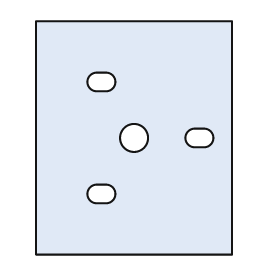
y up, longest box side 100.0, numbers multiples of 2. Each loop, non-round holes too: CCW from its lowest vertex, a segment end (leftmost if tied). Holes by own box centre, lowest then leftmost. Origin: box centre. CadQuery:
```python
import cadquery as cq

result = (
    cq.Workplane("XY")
    .moveTo(-42.0, -50.0)
    .lineTo(42.0, -50.0)
    .lineTo(42.0, 50.0)
    .lineTo(-42.0, 50.0)
    .close()
    .moveTo(-16.0, -28.0)
    .lineTo(-12.0, -28.0)
    .threePointArc((-8.0, -24.0), (-12.0, -20.0))
    .lineTo(-16.0, -20.0)
    .threePointArc((-20.0, -24.0), (-16.0, -28.0))
    .close()
    .moveTo(0.0, 0.0)
    .circle(6.0)
    .moveTo(26.0, -4.0)
    .lineTo(30.0, -4.0)
    .threePointArc((34.0, 0.0), (30.0, 4.0))
    .lineTo(26.0, 4.0)
    .threePointArc((22.0, 0.0), (26.0, -4.0))
    .close()
    .moveTo(-16.0, 20.0)
    .lineTo(-12.0, 20.0)
    .threePointArc((-8.0, 24.0), (-12.0, 28.0))
    .lineTo(-16.0, 28.0)
    .threePointArc((-20.0, 24.0), (-16.0, 20.0))
    .close()
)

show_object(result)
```